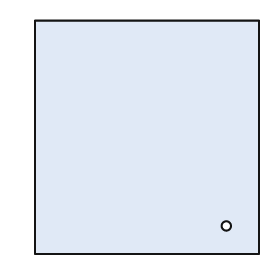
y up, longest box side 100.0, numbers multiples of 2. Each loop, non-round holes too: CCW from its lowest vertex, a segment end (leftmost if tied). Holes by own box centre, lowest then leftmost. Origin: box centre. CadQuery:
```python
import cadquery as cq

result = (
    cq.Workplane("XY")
    .moveTo(-48.0, -50.0)
    .lineTo(48.0, -50.0)
    .lineTo(48.0, 50.0)
    .lineTo(-48.0, 50.0)
    .close()
    .moveTo(34.0, -38.0)
    .circle(2.0)
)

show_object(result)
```